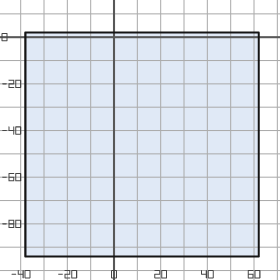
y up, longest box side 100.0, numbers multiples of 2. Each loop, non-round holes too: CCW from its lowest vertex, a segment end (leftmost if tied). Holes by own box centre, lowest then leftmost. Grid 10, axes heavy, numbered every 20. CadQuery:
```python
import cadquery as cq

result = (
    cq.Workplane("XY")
    .moveTo(-38.0, -94.0)
    .lineTo(62.0, -94.0)
    .lineTo(62.0, 2.0)
    .lineTo(-38.0, 2.0)
    .close()
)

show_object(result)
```